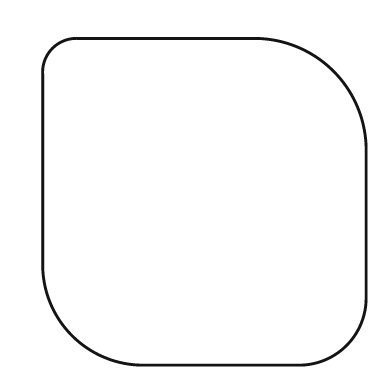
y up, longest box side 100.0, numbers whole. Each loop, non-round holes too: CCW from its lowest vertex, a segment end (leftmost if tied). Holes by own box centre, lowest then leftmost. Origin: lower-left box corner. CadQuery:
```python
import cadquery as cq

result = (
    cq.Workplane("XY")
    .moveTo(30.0, 0.0)
    .lineTo(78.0, 0.0)
    .threePointArc((93.0, 6.0), (99.0, 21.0))
    .lineTo(99.0, 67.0)
    .threePointArc((89.0, 90.0), (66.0, 100.0))
    .lineTo(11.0, 100.0)
    .threePointArc((3.0, 97.0), (0.0, 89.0))
    .lineTo(0.0, 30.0)
    .threePointArc((9.0, 9.0), (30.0, 0.0))
    .close()
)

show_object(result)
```